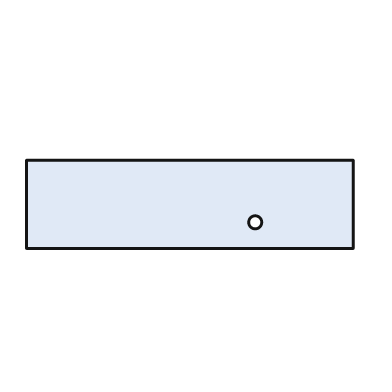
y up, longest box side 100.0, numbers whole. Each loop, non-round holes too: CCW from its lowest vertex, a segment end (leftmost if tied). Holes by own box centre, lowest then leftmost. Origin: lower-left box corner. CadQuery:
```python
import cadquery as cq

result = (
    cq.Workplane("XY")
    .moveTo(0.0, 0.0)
    .lineTo(100.0, 0.0)
    .lineTo(100.0, 27.0)
    .lineTo(0.0, 27.0)
    .close()
    .moveTo(70.0, 8.0)
    .circle(2.0)
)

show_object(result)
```